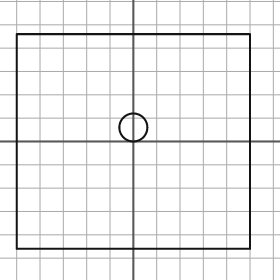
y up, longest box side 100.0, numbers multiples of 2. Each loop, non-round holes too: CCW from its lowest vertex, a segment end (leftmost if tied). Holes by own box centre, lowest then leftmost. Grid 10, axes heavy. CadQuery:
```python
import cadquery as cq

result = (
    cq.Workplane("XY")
    .moveTo(-50.0, -46.0)
    .lineTo(50.0, -46.0)
    .lineTo(50.0, 46.0)
    .lineTo(-50.0, 46.0)
    .close()
    .moveTo(0.0, 6.0)
    .circle(6.0)
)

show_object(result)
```